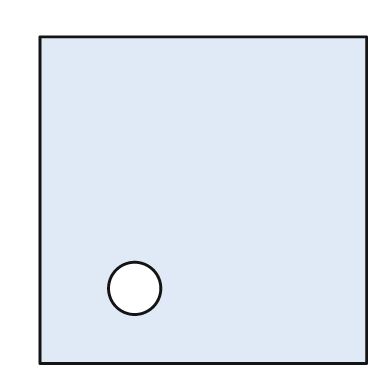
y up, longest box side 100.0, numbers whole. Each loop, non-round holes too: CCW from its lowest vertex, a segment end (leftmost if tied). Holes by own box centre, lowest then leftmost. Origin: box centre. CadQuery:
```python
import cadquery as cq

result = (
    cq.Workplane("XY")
    .moveTo(-50.0, -50.0)
    .lineTo(50.0, -50.0)
    .lineTo(50.0, 50.0)
    .lineTo(-50.0, 50.0)
    .close()
    .moveTo(-21.0, -27.0)
    .circle(8.0)
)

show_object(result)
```